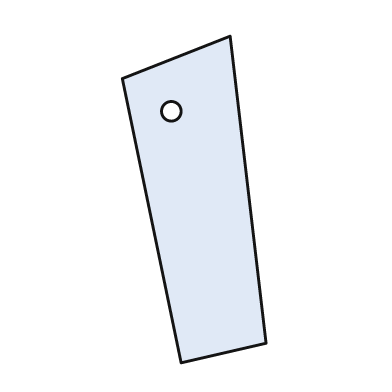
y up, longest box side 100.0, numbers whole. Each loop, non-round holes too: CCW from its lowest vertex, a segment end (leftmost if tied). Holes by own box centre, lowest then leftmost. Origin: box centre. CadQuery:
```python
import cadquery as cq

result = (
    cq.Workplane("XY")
    .moveTo(-4.0, -50.0)
    .lineTo(22.0, -44.0)
    .lineTo(11.0, 50.0)
    .lineTo(-22.0, 37.0)
    .close()
    .moveTo(-7.0, 27.0)
    .circle(3.0)
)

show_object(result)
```